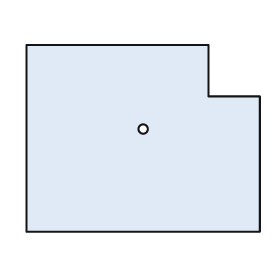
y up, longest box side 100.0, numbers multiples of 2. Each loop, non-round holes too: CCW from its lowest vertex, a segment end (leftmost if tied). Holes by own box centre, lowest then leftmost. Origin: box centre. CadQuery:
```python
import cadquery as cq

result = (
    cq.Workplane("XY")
    .moveTo(-50.0, -40.0)
    .lineTo(50.0, -40.0)
    .lineTo(50.0, 18.0)
    .lineTo(28.0, 18.0)
    .lineTo(28.0, 40.0)
    .lineTo(-50.0, 40.0)
    .close()
    .moveTo(0.0, 4.0)
    .circle(2.0)
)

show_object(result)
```